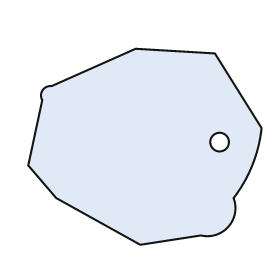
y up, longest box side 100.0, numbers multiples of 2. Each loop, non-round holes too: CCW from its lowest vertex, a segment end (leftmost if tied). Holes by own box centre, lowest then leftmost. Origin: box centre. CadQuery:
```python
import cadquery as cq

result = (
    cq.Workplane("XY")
    .moveTo(-2.0, -42.0)
    .lineTo(24.0, -38.0)
    .threePointArc((36.0, -34.0), (38.0, -22.0))
    .threePointArc((46.0, -8.0), (50.0, 8.0))
    .lineTo(30.0, 40.0)
    .lineTo(-4.0, 42.0)
    .lineTo(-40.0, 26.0)
    .threePointArc((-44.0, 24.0), (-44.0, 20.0))
    .lineTo(-50.0, -8.0)
    .lineTo(-38.0, -22.0)
    .close()
    .moveTo(32.0, 2.0)
    .circle(4.0)
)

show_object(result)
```